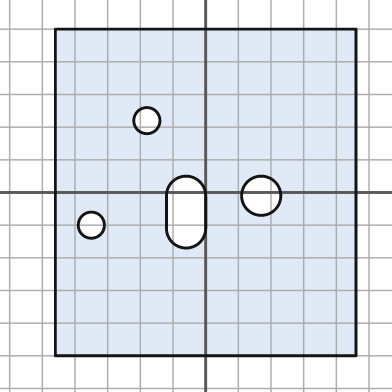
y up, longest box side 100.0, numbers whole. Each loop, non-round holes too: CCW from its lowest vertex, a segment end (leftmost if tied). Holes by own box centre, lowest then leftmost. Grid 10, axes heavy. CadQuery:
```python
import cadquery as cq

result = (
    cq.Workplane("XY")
    .moveTo(-46.0, -50.0)
    .lineTo(46.0, -50.0)
    .lineTo(46.0, 50.0)
    .lineTo(-46.0, 50.0)
    .close()
    .moveTo(-35.0, -10.0)
    .circle(4.0)
    .moveTo(-12.0, -11.0)
    .threePointArc((-6.0, -17.0), (0.0, -11.0))
    .lineTo(0.0, -1.0)
    .threePointArc((-6.0, 5.0), (-12.0, -1.0))
    .close()
    .moveTo(17.0, -1.0)
    .circle(6.0)
    .moveTo(-18.0, 22.0)
    .circle(4.0)
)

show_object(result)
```